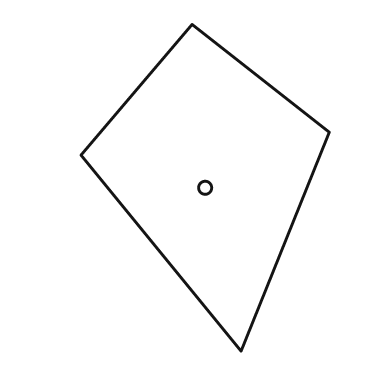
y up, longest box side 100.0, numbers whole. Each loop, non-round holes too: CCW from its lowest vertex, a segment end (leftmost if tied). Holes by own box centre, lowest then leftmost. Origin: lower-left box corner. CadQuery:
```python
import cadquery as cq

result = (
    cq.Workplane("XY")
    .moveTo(49.0, 0.0)
    .lineTo(76.0, 67.0)
    .lineTo(34.0, 100.0)
    .lineTo(0.0, 60.0)
    .close()
    .moveTo(38.0, 50.0)
    .circle(2.0)
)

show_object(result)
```